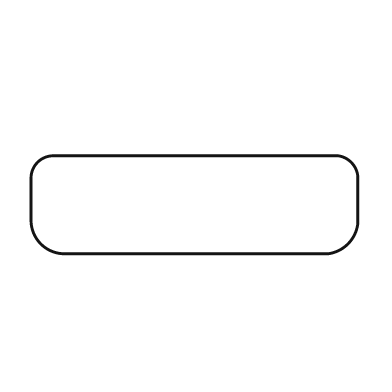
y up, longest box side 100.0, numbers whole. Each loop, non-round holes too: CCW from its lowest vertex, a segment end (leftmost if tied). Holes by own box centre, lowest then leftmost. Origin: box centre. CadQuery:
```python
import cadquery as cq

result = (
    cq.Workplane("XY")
    .moveTo(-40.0, -15.0)
    .lineTo(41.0, -15.0)
    .threePointArc((47.0, -12.0), (50.0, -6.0))
    .lineTo(50.0, 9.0)
    .threePointArc((48.0, 13.0), (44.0, 15.0))
    .lineTo(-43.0, 15.0)
    .threePointArc((-48.0, 13.0), (-50.0, 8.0))
    .lineTo(-50.0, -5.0)
    .threePointArc((-47.0, -12.0), (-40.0, -15.0))
    .close()
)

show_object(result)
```